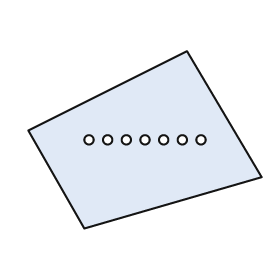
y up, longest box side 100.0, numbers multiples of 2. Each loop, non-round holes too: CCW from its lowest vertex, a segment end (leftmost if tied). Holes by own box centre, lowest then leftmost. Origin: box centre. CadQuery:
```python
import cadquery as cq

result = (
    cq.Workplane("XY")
    .moveTo(-26.0, -38.0)
    .lineTo(50.0, -16.0)
    .lineTo(18.0, 38.0)
    .lineTo(-50.0, 4.0)
    .close()
    .moveTo(-24.0, 0.0)
    .circle(2.0)
    .moveTo(-16.0, 0.0)
    .circle(2.0)
    .moveTo(-8.0, 0.0)
    .circle(2.0)
    .moveTo(0.0, 0.0)
    .circle(2.0)
    .moveTo(8.0, 0.0)
    .circle(2.0)
    .moveTo(16.0, 0.0)
    .circle(2.0)
    .moveTo(24.0, 0.0)
    .circle(2.0)
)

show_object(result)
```